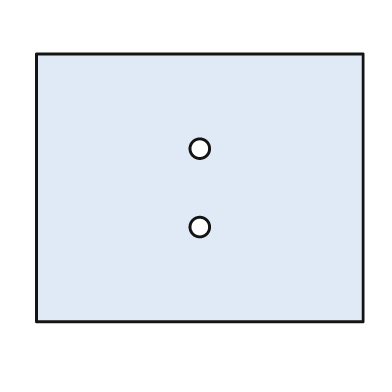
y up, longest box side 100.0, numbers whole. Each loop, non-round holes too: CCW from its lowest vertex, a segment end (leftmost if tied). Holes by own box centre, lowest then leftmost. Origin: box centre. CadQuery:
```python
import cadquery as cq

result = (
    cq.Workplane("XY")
    .moveTo(-50.0, -41.0)
    .lineTo(50.0, -41.0)
    .lineTo(50.0, 41.0)
    .lineTo(-50.0, 41.0)
    .close()
    .moveTo(0.0, -12.0)
    .circle(3.0)
    .moveTo(0.0, 12.0)
    .circle(3.0)
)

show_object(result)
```